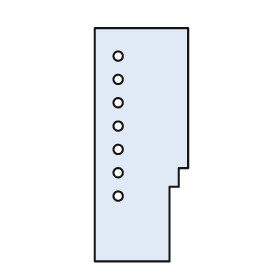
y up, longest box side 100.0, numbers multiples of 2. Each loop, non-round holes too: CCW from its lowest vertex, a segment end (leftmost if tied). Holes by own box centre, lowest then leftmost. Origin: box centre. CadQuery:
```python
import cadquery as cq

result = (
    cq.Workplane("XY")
    .moveTo(-20.0, -50.0)
    .lineTo(12.0, -50.0)
    .lineTo(12.0, -18.0)
    .lineTo(16.0, -18.0)
    .lineTo(16.0, -10.0)
    .lineTo(20.0, -10.0)
    .lineTo(20.0, 50.0)
    .lineTo(-20.0, 50.0)
    .close()
    .moveTo(-10.0, -22.0)
    .circle(2.0)
    .moveTo(-10.0, -12.0)
    .circle(2.0)
    .moveTo(-10.0, -2.0)
    .circle(2.0)
    .moveTo(-10.0, 8.0)
    .circle(2.0)
    .moveTo(-10.0, 18.0)
    .circle(2.0)
    .moveTo(-10.0, 28.0)
    .circle(2.0)
    .moveTo(-10.0, 38.0)
    .circle(2.0)
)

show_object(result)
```